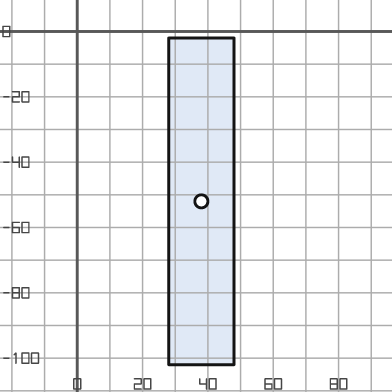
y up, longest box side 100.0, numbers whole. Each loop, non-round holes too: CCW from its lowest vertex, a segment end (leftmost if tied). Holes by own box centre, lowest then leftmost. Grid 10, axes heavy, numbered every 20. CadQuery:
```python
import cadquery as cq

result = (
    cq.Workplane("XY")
    .moveTo(28.0, -102.0)
    .lineTo(48.0, -102.0)
    .lineTo(48.0, -2.0)
    .lineTo(28.0, -2.0)
    .close()
    .moveTo(38.0, -52.0)
    .circle(2.0)
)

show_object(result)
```